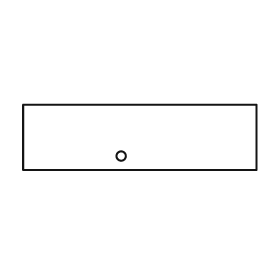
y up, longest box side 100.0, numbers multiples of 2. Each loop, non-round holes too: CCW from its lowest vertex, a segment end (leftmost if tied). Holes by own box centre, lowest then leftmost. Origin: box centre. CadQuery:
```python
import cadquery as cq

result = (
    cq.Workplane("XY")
    .moveTo(-50.0, -14.0)
    .lineTo(50.0, -14.0)
    .lineTo(50.0, 14.0)
    .lineTo(-50.0, 14.0)
    .close()
    .moveTo(-8.0, -8.0)
    .circle(2.0)
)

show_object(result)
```